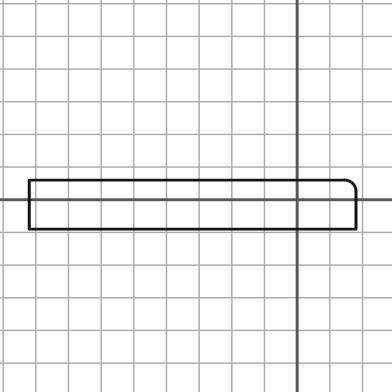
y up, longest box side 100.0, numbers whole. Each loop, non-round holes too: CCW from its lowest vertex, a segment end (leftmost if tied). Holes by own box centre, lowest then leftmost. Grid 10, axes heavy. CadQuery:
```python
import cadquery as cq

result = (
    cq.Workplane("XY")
    .moveTo(-82.0, -9.0)
    .lineTo(18.0, -9.0)
    .lineTo(18.0, 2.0)
    .threePointArc((17.0, 5.0), (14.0, 6.0))
    .lineTo(-82.0, 6.0)
    .close()
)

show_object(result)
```